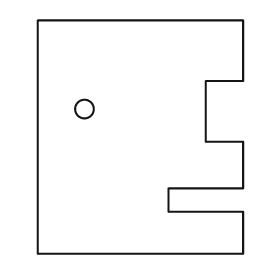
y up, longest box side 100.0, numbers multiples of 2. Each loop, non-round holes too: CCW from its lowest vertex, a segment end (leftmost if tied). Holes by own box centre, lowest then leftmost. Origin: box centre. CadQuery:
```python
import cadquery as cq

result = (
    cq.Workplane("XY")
    .moveTo(-44.0, -50.0)
    .lineTo(44.0, -50.0)
    .lineTo(44.0, -32.0)
    .lineTo(12.0, -32.0)
    .lineTo(12.0, -22.0)
    .lineTo(44.0, -22.0)
    .lineTo(44.0, -2.0)
    .lineTo(28.0, -2.0)
    .lineTo(28.0, 24.0)
    .lineTo(44.0, 24.0)
    .lineTo(44.0, 50.0)
    .lineTo(-44.0, 50.0)
    .close()
    .moveTo(-24.0, 12.0)
    .circle(4.0)
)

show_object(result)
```